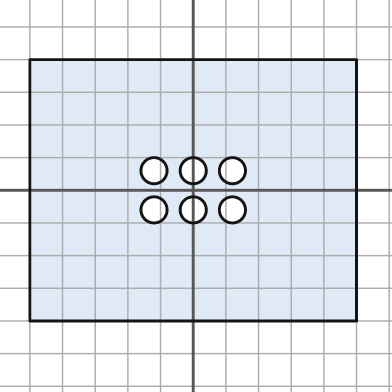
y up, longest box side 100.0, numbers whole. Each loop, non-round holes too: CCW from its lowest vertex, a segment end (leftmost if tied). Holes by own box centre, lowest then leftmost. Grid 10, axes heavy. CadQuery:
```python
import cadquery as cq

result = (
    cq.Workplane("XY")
    .moveTo(-50.0, -40.0)
    .lineTo(50.0, -40.0)
    .lineTo(50.0, 40.0)
    .lineTo(-50.0, 40.0)
    .close()
    .moveTo(-12.0, -6.0)
    .circle(4.0)
    .moveTo(0.0, -6.0)
    .circle(4.0)
    .moveTo(12.0, -6.0)
    .circle(4.0)
    .moveTo(-12.0, 6.0)
    .circle(4.0)
    .moveTo(0.0, 6.0)
    .circle(4.0)
    .moveTo(12.0, 6.0)
    .circle(4.0)
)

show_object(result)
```